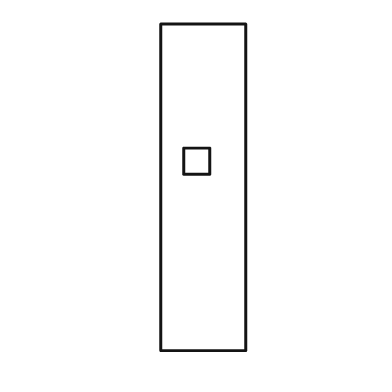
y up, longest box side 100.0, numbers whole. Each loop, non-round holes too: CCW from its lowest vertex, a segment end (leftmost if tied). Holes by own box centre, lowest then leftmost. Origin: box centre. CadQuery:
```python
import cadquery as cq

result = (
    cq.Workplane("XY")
    .moveTo(-13.0, -50.0)
    .lineTo(13.0, -50.0)
    .lineTo(13.0, 50.0)
    .lineTo(-13.0, 50.0)
    .close()
    .moveTo(-6.0, 4.0)
    .lineTo(2.0, 4.0)
    .lineTo(2.0, 12.0)
    .lineTo(-6.0, 12.0)
    .close()
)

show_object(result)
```